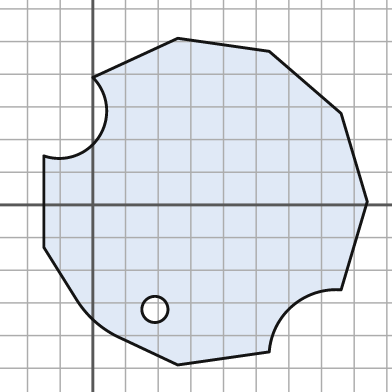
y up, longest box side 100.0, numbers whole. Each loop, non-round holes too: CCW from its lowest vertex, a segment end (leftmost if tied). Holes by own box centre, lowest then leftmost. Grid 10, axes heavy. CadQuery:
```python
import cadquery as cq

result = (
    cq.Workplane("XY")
    .moveTo(26.0, -49.0)
    .lineTo(54.0, -45.0)
    .threePointArc((61.0, -31.0), (76.0, -26.0))
    .lineTo(84.0, 1.0)
    .lineTo(76.0, 28.0)
    .lineTo(54.0, 47.0)
    .lineTo(26.0, 51.0)
    .lineTo(0.0, 39.0)
    .threePointArc((2.0, 21.0), (-15.0, 15.0))
    .lineTo(-15.0, -13.0)
    .lineTo(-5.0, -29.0)
    .threePointArc((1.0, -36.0), (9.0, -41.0))
    .close()
    .moveTo(19.0, -32.0)
    .circle(4.0)
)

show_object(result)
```